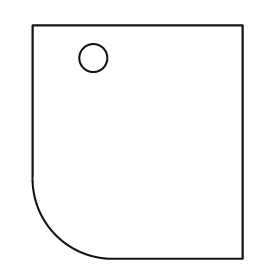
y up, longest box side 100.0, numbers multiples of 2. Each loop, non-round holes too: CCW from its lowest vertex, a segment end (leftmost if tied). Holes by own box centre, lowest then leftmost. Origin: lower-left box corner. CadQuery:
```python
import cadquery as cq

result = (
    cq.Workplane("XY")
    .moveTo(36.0, 0.0)
    .lineTo(90.0, 0.0)
    .lineTo(90.0, 100.0)
    .lineTo(0.0, 100.0)
    .lineTo(0.0, 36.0)
    .threePointArc((10.0, 10.0), (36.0, 0.0))
    .close()
    .moveTo(26.0, 86.0)
    .circle(6.0)
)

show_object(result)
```